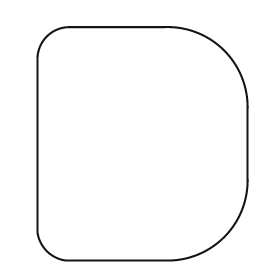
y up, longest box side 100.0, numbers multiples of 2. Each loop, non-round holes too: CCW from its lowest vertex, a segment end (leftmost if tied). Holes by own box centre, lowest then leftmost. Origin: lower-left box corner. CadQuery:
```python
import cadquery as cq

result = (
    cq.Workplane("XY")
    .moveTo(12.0, 0.0)
    .lineTo(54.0, 0.0)
    .threePointArc((80.0, 10.0), (90.0, 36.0))
    .lineTo(90.0, 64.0)
    .threePointArc((80.0, 90.0), (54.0, 100.0))
    .lineTo(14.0, 100.0)
    .threePointArc((4.0, 96.0), (0.0, 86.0))
    .lineTo(0.0, 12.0)
    .threePointArc((4.0, 4.0), (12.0, 0.0))
    .close()
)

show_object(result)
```